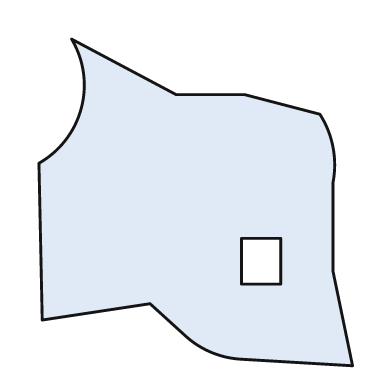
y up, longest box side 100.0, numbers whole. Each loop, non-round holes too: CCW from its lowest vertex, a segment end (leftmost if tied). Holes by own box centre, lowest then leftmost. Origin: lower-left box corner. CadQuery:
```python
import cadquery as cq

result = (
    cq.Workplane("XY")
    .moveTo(96.0, 0.0)
    .lineTo(90.0, 29.0)
    .lineTo(90.0, 56.0)
    .threePointArc((90.0, 67.0), (86.0, 77.0))
    .lineTo(63.0, 83.0)
    .lineTo(42.0, 83.0)
    .lineTo(10.0, 100.0)
    .threePointArc((13.0, 79.0), (0.0, 62.0))
    .lineTo(1.0, 14.0)
    .lineTo(34.0, 19.0)
    .lineTo(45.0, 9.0)
    .threePointArc((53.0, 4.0), (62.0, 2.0))
    .close()
    .moveTo(62.0, 25.0)
    .lineTo(74.0, 25.0)
    .lineTo(74.0, 39.0)
    .lineTo(62.0, 39.0)
    .close()
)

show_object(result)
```